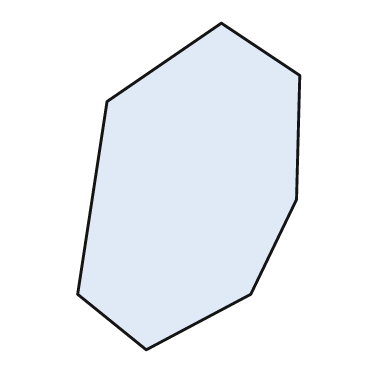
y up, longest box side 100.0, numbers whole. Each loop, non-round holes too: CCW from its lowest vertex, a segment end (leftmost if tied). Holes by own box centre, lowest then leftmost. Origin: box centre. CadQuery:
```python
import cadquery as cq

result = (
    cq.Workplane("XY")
    .moveTo(-13.0, -50.0)
    .lineTo(19.0, -33.0)
    .lineTo(33.0, -4.0)
    .lineTo(34.0, 34.0)
    .lineTo(10.0, 50.0)
    .lineTo(-25.0, 26.0)
    .lineTo(-34.0, -33.0)
    .close()
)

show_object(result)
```